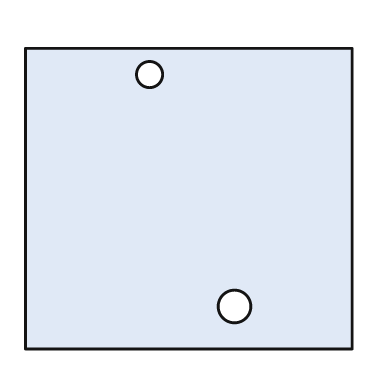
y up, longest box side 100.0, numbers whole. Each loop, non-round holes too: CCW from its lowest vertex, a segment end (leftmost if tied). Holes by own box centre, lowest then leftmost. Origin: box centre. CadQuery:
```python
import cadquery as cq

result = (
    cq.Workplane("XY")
    .moveTo(-50.0, -46.0)
    .lineTo(50.0, -46.0)
    .lineTo(50.0, 46.0)
    .lineTo(-50.0, 46.0)
    .close()
    .moveTo(14.0, -33.0)
    .circle(5.0)
    .moveTo(-12.0, 38.0)
    .circle(4.0)
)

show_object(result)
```